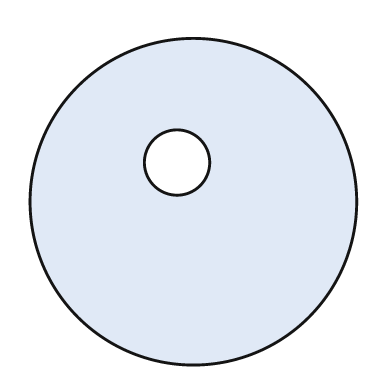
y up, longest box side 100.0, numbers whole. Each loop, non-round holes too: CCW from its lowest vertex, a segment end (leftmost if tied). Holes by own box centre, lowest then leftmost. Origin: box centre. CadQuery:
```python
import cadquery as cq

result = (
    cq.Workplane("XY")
    .moveTo(0.0, 0.0)
    .circle(50.0)
    .moveTo(-5.0, 12.0)
    .circle(10.0)
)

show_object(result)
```